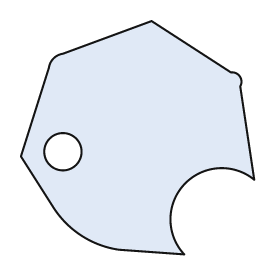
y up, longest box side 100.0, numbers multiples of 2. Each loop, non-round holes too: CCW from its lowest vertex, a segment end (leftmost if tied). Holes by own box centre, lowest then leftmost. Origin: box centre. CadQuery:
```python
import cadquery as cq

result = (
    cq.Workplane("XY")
    .moveTo(20.0, -50.0)
    .threePointArc((20.0, -20.0), (50.0, -18.0))
    .lineTo(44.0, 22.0)
    .threePointArc((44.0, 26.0), (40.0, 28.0))
    .lineTo(6.0, 50.0)
    .lineTo(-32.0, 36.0)
    .threePointArc((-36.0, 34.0), (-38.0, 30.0))
    .lineTo(-50.0, -8.0)
    .lineTo(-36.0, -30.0)
    .threePointArc((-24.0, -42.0), (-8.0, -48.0))
    .close()
    .moveTo(-32.0, -6.0)
    .circle(8.0)
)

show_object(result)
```